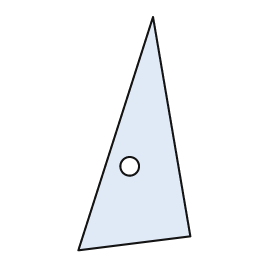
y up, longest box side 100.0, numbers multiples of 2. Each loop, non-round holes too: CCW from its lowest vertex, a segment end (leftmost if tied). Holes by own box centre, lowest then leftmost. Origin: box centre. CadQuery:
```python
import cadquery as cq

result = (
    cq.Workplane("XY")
    .moveTo(-24.0, -50.0)
    .lineTo(24.0, -44.0)
    .lineTo(8.0, 50.0)
    .close()
    .moveTo(-2.0, -14.0)
    .circle(4.0)
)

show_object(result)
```